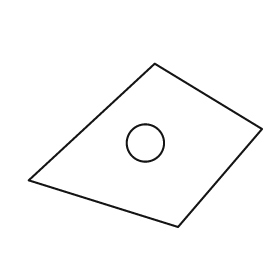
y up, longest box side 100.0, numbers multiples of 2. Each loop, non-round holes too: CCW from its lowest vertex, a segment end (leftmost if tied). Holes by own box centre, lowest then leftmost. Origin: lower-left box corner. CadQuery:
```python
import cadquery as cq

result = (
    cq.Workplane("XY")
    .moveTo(64.0, 0.0)
    .lineTo(100.0, 42.0)
    .lineTo(54.0, 70.0)
    .lineTo(0.0, 20.0)
    .close()
    .moveTo(50.0, 36.0)
    .circle(8.0)
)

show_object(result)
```